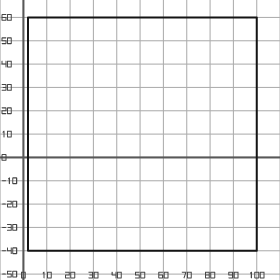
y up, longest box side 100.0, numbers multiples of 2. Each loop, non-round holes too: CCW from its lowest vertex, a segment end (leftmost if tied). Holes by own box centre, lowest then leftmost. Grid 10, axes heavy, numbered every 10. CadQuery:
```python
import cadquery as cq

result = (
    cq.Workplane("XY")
    .moveTo(2.0, -40.0)
    .lineTo(100.0, -40.0)
    .lineTo(100.0, 60.0)
    .lineTo(2.0, 60.0)
    .close()
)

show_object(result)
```